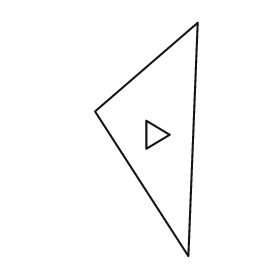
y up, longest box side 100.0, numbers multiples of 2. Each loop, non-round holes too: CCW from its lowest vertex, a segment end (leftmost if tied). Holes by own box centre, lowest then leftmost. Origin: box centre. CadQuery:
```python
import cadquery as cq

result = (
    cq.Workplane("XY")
    .moveTo(18.0, -50.0)
    .lineTo(22.0, 50.0)
    .lineTo(-22.0, 12.0)
    .close()
    .moveTo(0.0, -4.0)
    .lineTo(10.0, 2.0)
    .lineTo(0.0, 8.0)
    .close()
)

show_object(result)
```